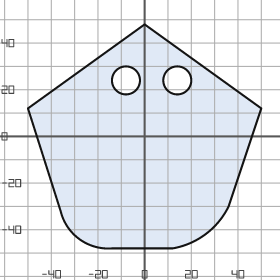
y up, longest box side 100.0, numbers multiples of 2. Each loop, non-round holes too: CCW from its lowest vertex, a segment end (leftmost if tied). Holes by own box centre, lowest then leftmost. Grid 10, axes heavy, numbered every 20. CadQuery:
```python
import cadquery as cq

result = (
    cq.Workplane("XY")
    .moveTo(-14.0, -48.0)
    .lineTo(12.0, -48.0)
    .threePointArc((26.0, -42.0), (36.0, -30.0))
    .lineTo(50.0, 12.0)
    .lineTo(0.0, 48.0)
    .lineTo(-50.0, 12.0)
    .lineTo(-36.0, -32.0)
    .threePointArc((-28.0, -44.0), (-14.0, -48.0))
    .close()
    .moveTo(-8.0, 24.0)
    .circle(6.0)
    .moveTo(14.0, 24.0)
    .circle(6.0)
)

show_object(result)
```